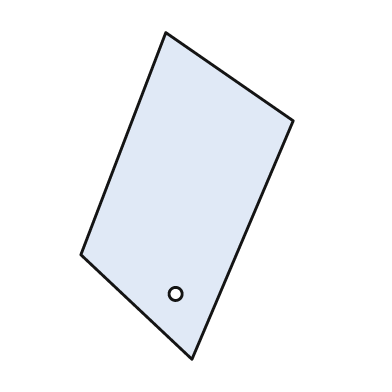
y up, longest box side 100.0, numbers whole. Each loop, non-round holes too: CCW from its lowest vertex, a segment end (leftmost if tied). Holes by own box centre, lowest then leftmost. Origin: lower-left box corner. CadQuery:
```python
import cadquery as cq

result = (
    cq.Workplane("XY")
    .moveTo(34.0, 0.0)
    .lineTo(65.0, 73.0)
    .lineTo(26.0, 100.0)
    .lineTo(0.0, 32.0)
    .close()
    .moveTo(29.0, 20.0)
    .circle(2.0)
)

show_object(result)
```